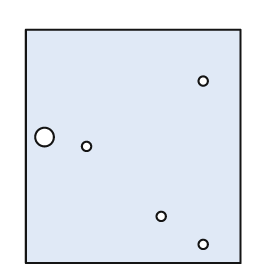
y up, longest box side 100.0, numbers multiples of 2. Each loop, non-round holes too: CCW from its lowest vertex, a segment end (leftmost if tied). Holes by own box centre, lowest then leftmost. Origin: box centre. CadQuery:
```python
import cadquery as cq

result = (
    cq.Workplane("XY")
    .moveTo(-46.0, -50.0)
    .lineTo(46.0, -50.0)
    .lineTo(46.0, 50.0)
    .lineTo(-46.0, 50.0)
    .close()
    .moveTo(30.0, -42.0)
    .circle(2.0)
    .moveTo(12.0, -30.0)
    .circle(2.0)
    .moveTo(-20.0, 0.0)
    .circle(2.0)
    .moveTo(-38.0, 4.0)
    .circle(4.0)
    .moveTo(30.0, 28.0)
    .circle(2.0)
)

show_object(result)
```